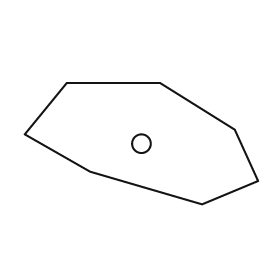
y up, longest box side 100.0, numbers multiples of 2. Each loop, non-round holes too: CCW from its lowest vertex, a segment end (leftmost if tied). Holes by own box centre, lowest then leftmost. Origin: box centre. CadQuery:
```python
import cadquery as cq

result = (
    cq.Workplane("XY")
    .moveTo(26.0, -26.0)
    .lineTo(50.0, -16.0)
    .lineTo(40.0, 6.0)
    .lineTo(8.0, 26.0)
    .lineTo(-32.0, 26.0)
    .lineTo(-50.0, 4.0)
    .lineTo(-22.0, -12.0)
    .close()
    .moveTo(0.0, 0.0)
    .circle(4.0)
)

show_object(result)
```